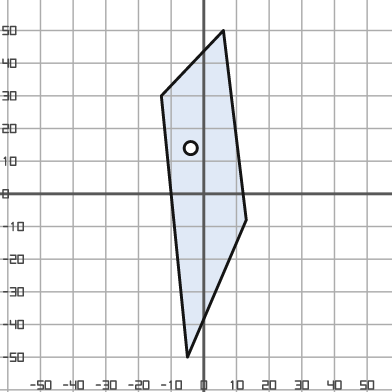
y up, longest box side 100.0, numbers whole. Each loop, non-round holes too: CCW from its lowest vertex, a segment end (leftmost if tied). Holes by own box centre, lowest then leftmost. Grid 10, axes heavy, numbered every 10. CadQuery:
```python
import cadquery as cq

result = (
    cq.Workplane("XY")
    .moveTo(-5.0, -50.0)
    .lineTo(13.0, -8.0)
    .lineTo(6.0, 50.0)
    .lineTo(-13.0, 30.0)
    .close()
    .moveTo(-4.0, 14.0)
    .circle(2.0)
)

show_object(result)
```